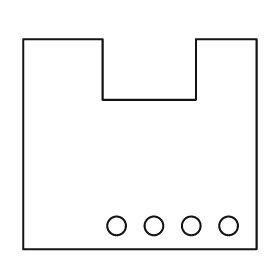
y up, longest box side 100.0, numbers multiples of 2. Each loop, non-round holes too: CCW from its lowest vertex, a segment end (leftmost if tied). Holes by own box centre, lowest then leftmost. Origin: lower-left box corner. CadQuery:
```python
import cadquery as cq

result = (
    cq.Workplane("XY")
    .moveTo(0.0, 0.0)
    .lineTo(100.0, 0.0)
    .lineTo(100.0, 90.0)
    .lineTo(74.0, 90.0)
    .lineTo(74.0, 64.0)
    .lineTo(34.0, 64.0)
    .lineTo(34.0, 90.0)
    .lineTo(0.0, 90.0)
    .close()
    .moveTo(40.0, 10.0)
    .circle(4.0)
    .moveTo(56.0, 10.0)
    .circle(4.0)
    .moveTo(72.0, 10.0)
    .circle(4.0)
    .moveTo(88.0, 10.0)
    .circle(4.0)
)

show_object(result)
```